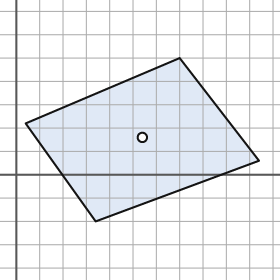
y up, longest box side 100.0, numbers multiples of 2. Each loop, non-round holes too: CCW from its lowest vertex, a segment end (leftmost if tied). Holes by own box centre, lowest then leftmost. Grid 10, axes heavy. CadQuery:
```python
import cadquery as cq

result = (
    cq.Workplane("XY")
    .moveTo(34.0, -20.0)
    .lineTo(104.0, 6.0)
    .lineTo(70.0, 50.0)
    .lineTo(4.0, 22.0)
    .close()
    .moveTo(54.0, 16.0)
    .circle(2.0)
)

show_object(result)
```